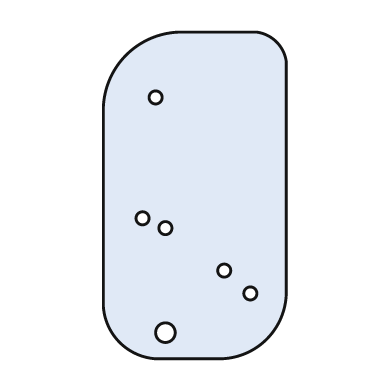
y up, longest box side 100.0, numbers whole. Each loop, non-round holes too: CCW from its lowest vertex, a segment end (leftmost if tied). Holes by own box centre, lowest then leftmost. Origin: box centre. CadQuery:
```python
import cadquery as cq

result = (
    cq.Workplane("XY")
    .moveTo(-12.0, -50.0)
    .lineTo(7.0, -50.0)
    .threePointArc((22.0, -44.0), (28.0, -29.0))
    .lineTo(28.0, 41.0)
    .threePointArc((25.0, 47.0), (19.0, 50.0))
    .lineTo(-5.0, 50.0)
    .threePointArc((-21.0, 43.0), (-28.0, 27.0))
    .lineTo(-28.0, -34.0)
    .threePointArc((-23.0, -45.0), (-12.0, -50.0))
    .close()
    .moveTo(-9.0, -42.0)
    .circle(3.0)
    .moveTo(17.0, -30.0)
    .circle(2.0)
    .moveTo(9.0, -23.0)
    .circle(2.0)
    .moveTo(-9.0, -10.0)
    .circle(2.0)
    .moveTo(-16.0, -7.0)
    .circle(2.0)
    .moveTo(-12.0, 30.0)
    .circle(2.0)
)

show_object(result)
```